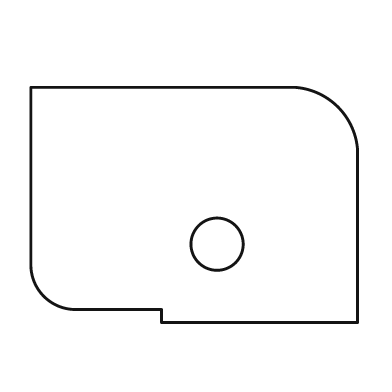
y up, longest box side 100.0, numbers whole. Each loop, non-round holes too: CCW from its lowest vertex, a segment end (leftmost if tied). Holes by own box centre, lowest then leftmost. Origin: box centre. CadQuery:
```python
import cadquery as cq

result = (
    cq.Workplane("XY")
    .moveTo(-10.0, -36.0)
    .lineTo(50.0, -36.0)
    .lineTo(50.0, 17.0)
    .threePointArc((44.0, 30.0), (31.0, 36.0))
    .lineTo(-50.0, 36.0)
    .lineTo(-50.0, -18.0)
    .threePointArc((-46.0, -28.0), (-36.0, -32.0))
    .lineTo(-10.0, -32.0)
    .close()
    .moveTo(7.0, -12.0)
    .circle(8.0)
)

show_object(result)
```